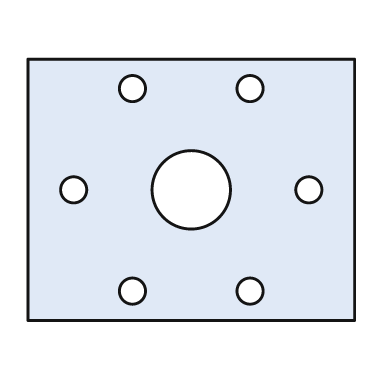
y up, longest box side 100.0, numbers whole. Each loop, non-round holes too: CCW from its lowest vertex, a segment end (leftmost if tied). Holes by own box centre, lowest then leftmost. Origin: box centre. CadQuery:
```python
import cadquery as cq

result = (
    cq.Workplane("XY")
    .moveTo(-50.0, -40.0)
    .lineTo(50.0, -40.0)
    .lineTo(50.0, 40.0)
    .lineTo(-50.0, 40.0)
    .close()
    .moveTo(-18.0, -31.0)
    .circle(4.0)
    .moveTo(18.0, -31.0)
    .circle(4.0)
    .moveTo(-36.0, 0.0)
    .circle(4.0)
    .moveTo(0.0, 0.0)
    .circle(12.0)
    .moveTo(36.0, 0.0)
    .circle(4.0)
    .moveTo(-18.0, 31.0)
    .circle(4.0)
    .moveTo(18.0, 31.0)
    .circle(4.0)
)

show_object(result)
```